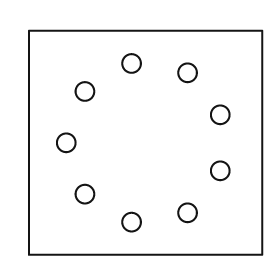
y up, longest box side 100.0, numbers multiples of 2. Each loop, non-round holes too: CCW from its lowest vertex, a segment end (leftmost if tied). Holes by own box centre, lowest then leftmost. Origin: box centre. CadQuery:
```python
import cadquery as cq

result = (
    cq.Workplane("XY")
    .moveTo(-50.0, -48.0)
    .lineTo(50.0, -48.0)
    .lineTo(50.0, 48.0)
    .lineTo(-50.0, 48.0)
    .close()
    .moveTo(-6.0, -34.0)
    .circle(4.0)
    .moveTo(18.0, -30.0)
    .circle(4.0)
    .moveTo(-26.0, -22.0)
    .circle(4.0)
    .moveTo(32.0, -12.0)
    .circle(4.0)
    .moveTo(-34.0, 0.0)
    .circle(4.0)
    .moveTo(32.0, 12.0)
    .circle(4.0)
    .moveTo(-26.0, 22.0)
    .circle(4.0)
    .moveTo(18.0, 30.0)
    .circle(4.0)
    .moveTo(-6.0, 34.0)
    .circle(4.0)
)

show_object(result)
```